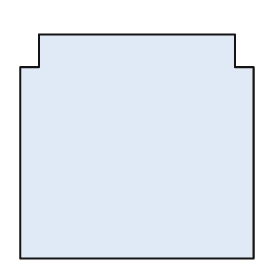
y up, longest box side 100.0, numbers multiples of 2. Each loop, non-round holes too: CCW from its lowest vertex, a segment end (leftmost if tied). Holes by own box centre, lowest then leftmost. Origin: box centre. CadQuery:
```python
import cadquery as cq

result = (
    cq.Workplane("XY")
    .moveTo(-50.0, -48.0)
    .lineTo(50.0, -48.0)
    .lineTo(50.0, 34.0)
    .lineTo(42.0, 34.0)
    .lineTo(42.0, 48.0)
    .lineTo(-42.0, 48.0)
    .lineTo(-42.0, 34.0)
    .lineTo(-50.0, 34.0)
    .close()
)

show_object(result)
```